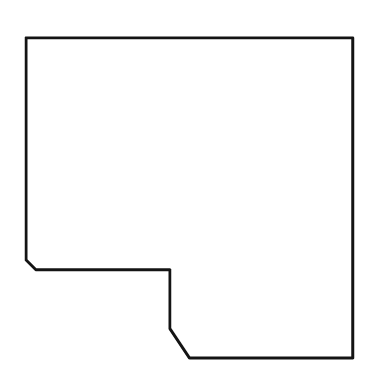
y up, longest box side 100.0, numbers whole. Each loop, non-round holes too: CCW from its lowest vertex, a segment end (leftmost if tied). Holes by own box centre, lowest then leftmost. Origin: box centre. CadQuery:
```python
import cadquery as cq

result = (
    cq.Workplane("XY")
    .moveTo(0.0, -49.0)
    .lineTo(50.0, -49.0)
    .lineTo(50.0, 49.0)
    .lineTo(-50.0, 49.0)
    .lineTo(-50.0, -19.0)
    .lineTo(-47.0, -22.0)
    .lineTo(-6.0, -22.0)
    .lineTo(-6.0, -40.0)
    .close()
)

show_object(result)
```